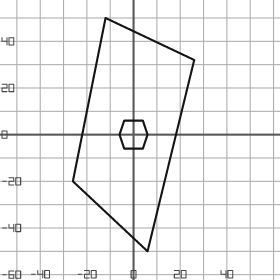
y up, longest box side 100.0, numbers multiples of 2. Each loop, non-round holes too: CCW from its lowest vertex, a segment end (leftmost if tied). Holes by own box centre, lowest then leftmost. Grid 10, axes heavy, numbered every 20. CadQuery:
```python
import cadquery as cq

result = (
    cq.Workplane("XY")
    .moveTo(6.0, -50.0)
    .lineTo(26.0, 32.0)
    .lineTo(-12.0, 50.0)
    .lineTo(-26.0, -20.0)
    .close()
    .moveTo(-4.0, -6.0)
    .lineTo(4.0, -6.0)
    .lineTo(6.0, 0.0)
    .lineTo(4.0, 6.0)
    .lineTo(-4.0, 6.0)
    .lineTo(-6.0, 0.0)
    .close()
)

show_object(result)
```